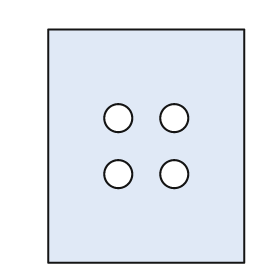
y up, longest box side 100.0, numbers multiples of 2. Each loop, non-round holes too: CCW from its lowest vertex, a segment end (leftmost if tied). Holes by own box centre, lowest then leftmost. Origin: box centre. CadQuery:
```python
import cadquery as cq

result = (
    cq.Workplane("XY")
    .moveTo(-42.0, -50.0)
    .lineTo(42.0, -50.0)
    .lineTo(42.0, 50.0)
    .lineTo(-42.0, 50.0)
    .close()
    .moveTo(-12.0, -12.0)
    .circle(6.0)
    .moveTo(12.0, -12.0)
    .circle(6.0)
    .moveTo(-12.0, 12.0)
    .circle(6.0)
    .moveTo(12.0, 12.0)
    .circle(6.0)
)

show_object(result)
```